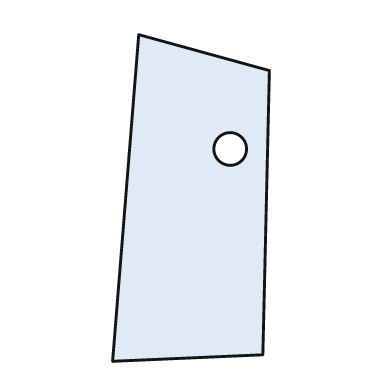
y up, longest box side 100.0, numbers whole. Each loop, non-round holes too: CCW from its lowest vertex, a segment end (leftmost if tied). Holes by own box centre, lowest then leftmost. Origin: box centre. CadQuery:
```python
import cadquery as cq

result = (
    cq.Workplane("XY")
    .moveTo(-24.0, -50.0)
    .lineTo(22.0, -48.0)
    .lineTo(24.0, 39.0)
    .lineTo(-16.0, 50.0)
    .close()
    .moveTo(12.0, 15.0)
    .circle(5.0)
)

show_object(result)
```